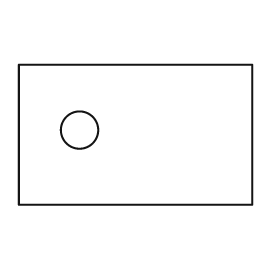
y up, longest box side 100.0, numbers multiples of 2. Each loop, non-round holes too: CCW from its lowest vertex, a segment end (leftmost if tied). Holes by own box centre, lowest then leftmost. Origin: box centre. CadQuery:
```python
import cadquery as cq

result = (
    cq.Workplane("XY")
    .moveTo(-50.0, -30.0)
    .lineTo(50.0, -30.0)
    .lineTo(50.0, 30.0)
    .lineTo(-50.0, 30.0)
    .close()
    .moveTo(-24.0, 2.0)
    .circle(8.0)
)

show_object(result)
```